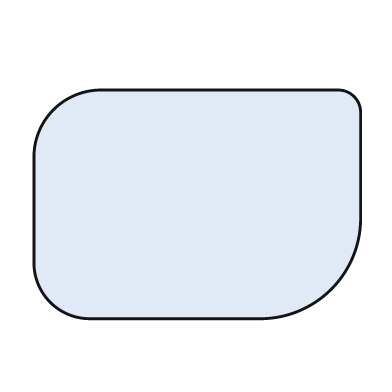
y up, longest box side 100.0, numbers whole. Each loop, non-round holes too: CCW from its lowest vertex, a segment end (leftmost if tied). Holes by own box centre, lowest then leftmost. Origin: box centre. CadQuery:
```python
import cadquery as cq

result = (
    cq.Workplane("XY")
    .moveTo(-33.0, -35.0)
    .lineTo(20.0, -35.0)
    .threePointArc((41.0, -26.0), (50.0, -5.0))
    .lineTo(50.0, 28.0)
    .threePointArc((48.0, 33.0), (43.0, 35.0))
    .lineTo(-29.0, 35.0)
    .threePointArc((-44.0, 29.0), (-50.0, 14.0))
    .lineTo(-50.0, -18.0)
    .threePointArc((-45.0, -30.0), (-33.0, -35.0))
    .close()
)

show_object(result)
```